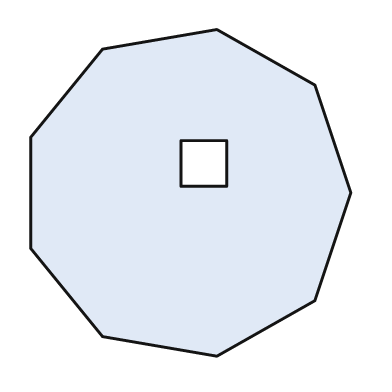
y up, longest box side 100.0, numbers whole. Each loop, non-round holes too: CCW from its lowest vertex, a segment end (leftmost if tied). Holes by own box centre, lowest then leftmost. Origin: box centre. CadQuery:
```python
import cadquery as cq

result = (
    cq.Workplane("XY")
    .moveTo(8.0, -50.0)
    .lineTo(38.0, -33.0)
    .lineTo(49.0, 0.0)
    .lineTo(38.0, 33.0)
    .lineTo(8.0, 50.0)
    .lineTo(-27.0, 44.0)
    .lineTo(-49.0, 17.0)
    .lineTo(-49.0, -17.0)
    .lineTo(-27.0, -44.0)
    .close()
    .moveTo(-3.0, 2.0)
    .lineTo(11.0, 2.0)
    .lineTo(11.0, 16.0)
    .lineTo(-3.0, 16.0)
    .close()
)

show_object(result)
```